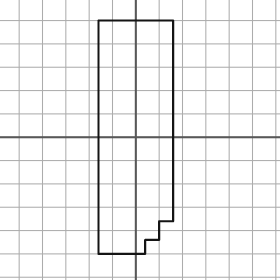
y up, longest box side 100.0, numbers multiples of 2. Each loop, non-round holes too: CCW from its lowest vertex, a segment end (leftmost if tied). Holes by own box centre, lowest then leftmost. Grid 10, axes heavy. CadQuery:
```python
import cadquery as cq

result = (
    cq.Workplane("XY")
    .moveTo(-16.0, -50.0)
    .lineTo(4.0, -50.0)
    .lineTo(4.0, -44.0)
    .lineTo(10.0, -44.0)
    .lineTo(10.0, -36.0)
    .lineTo(16.0, -36.0)
    .lineTo(16.0, 50.0)
    .lineTo(-16.0, 50.0)
    .close()
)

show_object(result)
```